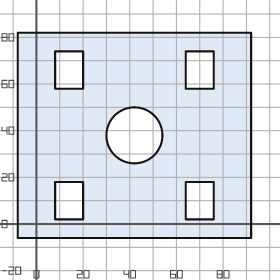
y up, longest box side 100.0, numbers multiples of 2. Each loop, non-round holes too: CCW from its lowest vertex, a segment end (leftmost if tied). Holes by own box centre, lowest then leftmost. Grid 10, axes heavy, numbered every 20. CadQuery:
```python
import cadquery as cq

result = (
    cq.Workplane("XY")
    .moveTo(-8.0, -6.0)
    .lineTo(92.0, -6.0)
    .lineTo(92.0, 82.0)
    .lineTo(-8.0, 82.0)
    .close()
    .moveTo(8.0, 2.0)
    .lineTo(20.0, 2.0)
    .lineTo(20.0, 18.0)
    .lineTo(8.0, 18.0)
    .close()
    .moveTo(64.0, 2.0)
    .lineTo(76.0, 2.0)
    .lineTo(76.0, 18.0)
    .lineTo(64.0, 18.0)
    .close()
    .moveTo(42.0, 38.0)
    .circle(12.0)
    .moveTo(8.0, 58.0)
    .lineTo(20.0, 58.0)
    .lineTo(20.0, 74.0)
    .lineTo(8.0, 74.0)
    .close()
    .moveTo(64.0, 58.0)
    .lineTo(76.0, 58.0)
    .lineTo(76.0, 74.0)
    .lineTo(64.0, 74.0)
    .close()
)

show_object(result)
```